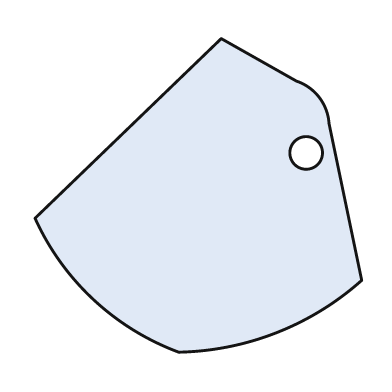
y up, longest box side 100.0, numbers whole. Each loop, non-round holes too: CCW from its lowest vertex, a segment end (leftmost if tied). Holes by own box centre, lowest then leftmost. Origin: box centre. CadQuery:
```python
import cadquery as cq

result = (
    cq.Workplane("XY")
    .moveTo(-6.0, -48.0)
    .threePointArc((24.0, -42.0), (50.0, -26.0))
    .lineTo(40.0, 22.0)
    .threePointArc((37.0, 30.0), (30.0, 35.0))
    .lineTo(7.0, 48.0)
    .lineTo(-50.0, -7.0)
    .threePointArc((-32.0, -32.0), (-6.0, -48.0))
    .close()
    .moveTo(33.0, 13.0)
    .circle(5.0)
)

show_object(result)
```